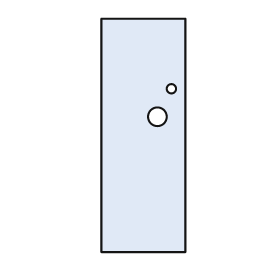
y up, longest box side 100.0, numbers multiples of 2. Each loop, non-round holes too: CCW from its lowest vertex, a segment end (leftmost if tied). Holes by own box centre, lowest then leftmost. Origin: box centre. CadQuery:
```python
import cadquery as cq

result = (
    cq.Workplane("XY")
    .moveTo(-18.0, -50.0)
    .lineTo(18.0, -50.0)
    .lineTo(18.0, 50.0)
    .lineTo(-18.0, 50.0)
    .close()
    .moveTo(6.0, 8.0)
    .circle(4.0)
    .moveTo(12.0, 20.0)
    .circle(2.0)
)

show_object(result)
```